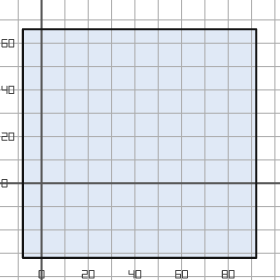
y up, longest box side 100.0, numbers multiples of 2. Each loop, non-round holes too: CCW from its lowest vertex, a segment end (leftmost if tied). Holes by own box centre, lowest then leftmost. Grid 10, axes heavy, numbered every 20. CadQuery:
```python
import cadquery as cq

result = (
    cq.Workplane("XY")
    .moveTo(-8.0, -32.0)
    .lineTo(92.0, -32.0)
    .lineTo(92.0, 66.0)
    .lineTo(-8.0, 66.0)
    .close()
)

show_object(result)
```